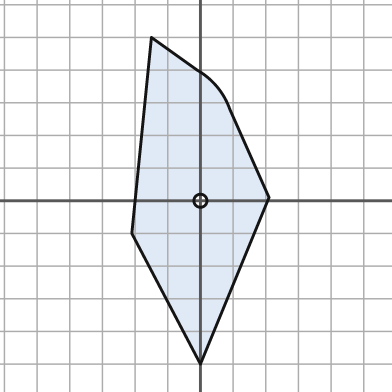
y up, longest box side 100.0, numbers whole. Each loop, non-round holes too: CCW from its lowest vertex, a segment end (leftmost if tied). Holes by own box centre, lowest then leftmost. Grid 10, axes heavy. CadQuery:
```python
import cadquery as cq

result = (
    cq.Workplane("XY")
    .moveTo(0.0, -50.0)
    .lineTo(21.0, 1.0)
    .lineTo(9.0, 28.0)
    .threePointArc((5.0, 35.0), (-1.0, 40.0))
    .lineTo(-15.0, 50.0)
    .lineTo(-21.0, -10.0)
    .close()
    .moveTo(0.0, 0.0)
    .circle(2.0)
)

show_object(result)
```